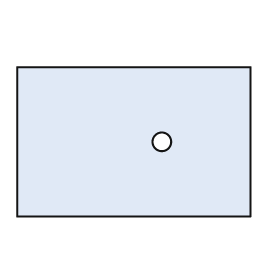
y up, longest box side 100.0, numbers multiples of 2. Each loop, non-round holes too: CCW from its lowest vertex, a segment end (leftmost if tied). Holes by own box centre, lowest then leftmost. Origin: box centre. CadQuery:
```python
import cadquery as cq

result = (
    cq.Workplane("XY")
    .moveTo(-50.0, -32.0)
    .lineTo(50.0, -32.0)
    .lineTo(50.0, 32.0)
    .lineTo(-50.0, 32.0)
    .close()
    .moveTo(12.0, 0.0)
    .circle(4.0)
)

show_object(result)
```